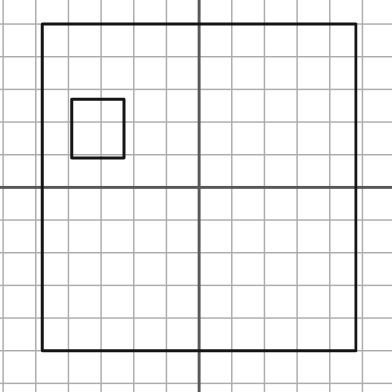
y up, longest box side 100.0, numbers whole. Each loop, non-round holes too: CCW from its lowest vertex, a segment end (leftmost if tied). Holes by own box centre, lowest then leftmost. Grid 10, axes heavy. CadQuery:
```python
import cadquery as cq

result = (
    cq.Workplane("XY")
    .moveTo(-48.0, -50.0)
    .lineTo(48.0, -50.0)
    .lineTo(48.0, 50.0)
    .lineTo(-48.0, 50.0)
    .close()
    .moveTo(-39.0, 9.0)
    .lineTo(-23.0, 9.0)
    .lineTo(-23.0, 27.0)
    .lineTo(-39.0, 27.0)
    .close()
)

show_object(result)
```